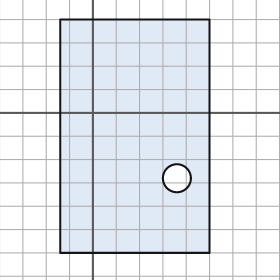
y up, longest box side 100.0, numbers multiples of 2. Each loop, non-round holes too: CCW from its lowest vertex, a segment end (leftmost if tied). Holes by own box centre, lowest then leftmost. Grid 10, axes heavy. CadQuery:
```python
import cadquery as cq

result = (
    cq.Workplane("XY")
    .moveTo(-14.0, -60.0)
    .lineTo(50.0, -60.0)
    .lineTo(50.0, 40.0)
    .lineTo(-14.0, 40.0)
    .close()
    .moveTo(36.0, -28.0)
    .circle(6.0)
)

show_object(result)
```